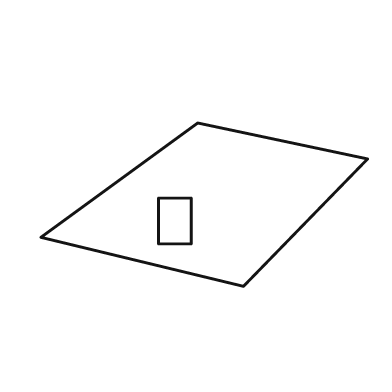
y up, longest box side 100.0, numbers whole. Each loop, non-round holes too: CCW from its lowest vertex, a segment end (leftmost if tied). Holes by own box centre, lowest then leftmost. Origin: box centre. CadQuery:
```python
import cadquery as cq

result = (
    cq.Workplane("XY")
    .moveTo(12.0, -25.0)
    .lineTo(50.0, 14.0)
    .lineTo(-2.0, 25.0)
    .lineTo(-50.0, -10.0)
    .close()
    .moveTo(-14.0, -12.0)
    .lineTo(-4.0, -12.0)
    .lineTo(-4.0, 2.0)
    .lineTo(-14.0, 2.0)
    .close()
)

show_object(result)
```